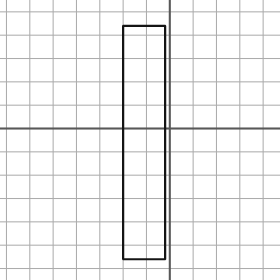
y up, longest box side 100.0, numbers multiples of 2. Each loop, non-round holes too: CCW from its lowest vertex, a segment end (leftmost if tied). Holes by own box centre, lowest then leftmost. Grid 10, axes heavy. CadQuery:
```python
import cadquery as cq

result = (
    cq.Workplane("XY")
    .moveTo(-20.0, -56.0)
    .lineTo(-2.0, -56.0)
    .lineTo(-2.0, 44.0)
    .lineTo(-20.0, 44.0)
    .close()
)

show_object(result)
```